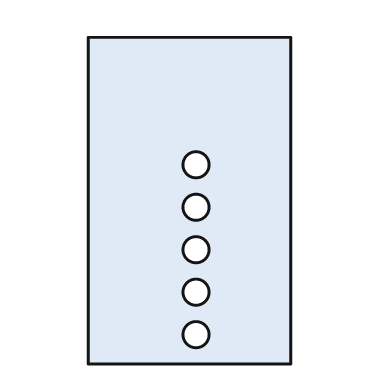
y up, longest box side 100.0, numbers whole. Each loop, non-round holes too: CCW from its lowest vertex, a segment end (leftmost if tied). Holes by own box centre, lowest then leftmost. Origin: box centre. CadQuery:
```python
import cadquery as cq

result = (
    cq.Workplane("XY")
    .moveTo(-31.0, -50.0)
    .lineTo(31.0, -50.0)
    .lineTo(31.0, 50.0)
    .lineTo(-31.0, 50.0)
    .close()
    .moveTo(2.0, -41.0)
    .circle(4.0)
    .moveTo(2.0, -28.0)
    .circle(4.0)
    .moveTo(2.0, -15.0)
    .circle(4.0)
    .moveTo(2.0, -2.0)
    .circle(4.0)
    .moveTo(2.0, 11.0)
    .circle(4.0)
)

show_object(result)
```